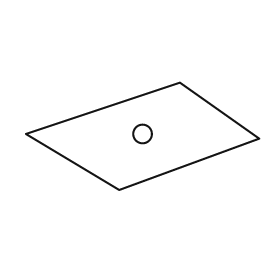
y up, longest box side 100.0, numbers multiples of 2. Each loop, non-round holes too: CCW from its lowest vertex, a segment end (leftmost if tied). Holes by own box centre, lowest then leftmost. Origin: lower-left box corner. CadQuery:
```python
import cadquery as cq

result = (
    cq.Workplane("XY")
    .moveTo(40.0, 0.0)
    .lineTo(100.0, 22.0)
    .lineTo(66.0, 46.0)
    .lineTo(0.0, 24.0)
    .close()
    .moveTo(50.0, 24.0)
    .circle(4.0)
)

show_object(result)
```